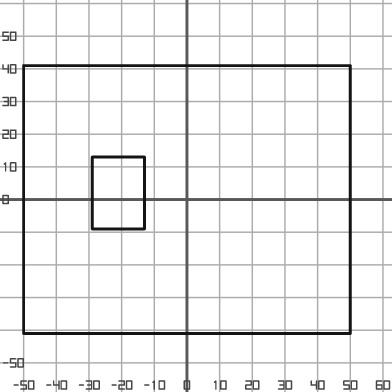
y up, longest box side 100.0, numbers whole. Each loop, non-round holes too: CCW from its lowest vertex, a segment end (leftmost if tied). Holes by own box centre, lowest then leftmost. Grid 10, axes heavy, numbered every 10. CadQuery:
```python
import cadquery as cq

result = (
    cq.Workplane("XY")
    .moveTo(-50.0, -41.0)
    .lineTo(50.0, -41.0)
    .lineTo(50.0, 41.0)
    .lineTo(-50.0, 41.0)
    .close()
    .moveTo(-29.0, -9.0)
    .lineTo(-13.0, -9.0)
    .lineTo(-13.0, 13.0)
    .lineTo(-29.0, 13.0)
    .close()
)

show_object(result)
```